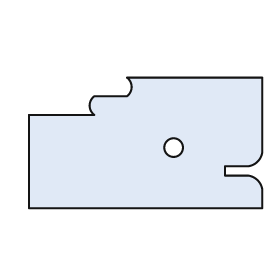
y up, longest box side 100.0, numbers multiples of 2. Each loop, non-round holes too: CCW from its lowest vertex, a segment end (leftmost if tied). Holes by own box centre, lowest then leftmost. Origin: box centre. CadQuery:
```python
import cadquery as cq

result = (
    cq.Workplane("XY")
    .moveTo(-50.0, -28.0)
    .lineTo(50.0, -28.0)
    .lineTo(50.0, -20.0)
    .threePointArc((48.0, -16.0), (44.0, -14.0))
    .lineTo(34.0, -14.0)
    .lineTo(34.0, -10.0)
    .lineTo(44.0, -10.0)
    .threePointArc((48.0, -8.0), (50.0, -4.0))
    .lineTo(50.0, 28.0)
    .lineTo(-8.0, 28.0)
    .threePointArc((-6.0, 24.0), (-8.0, 20.0))
    .lineTo(-22.0, 20.0)
    .threePointArc((-24.0, 16.0), (-22.0, 12.0))
    .lineTo(-50.0, 12.0)
    .close()
    .moveTo(12.0, -2.0)
    .circle(4.0)
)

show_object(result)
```